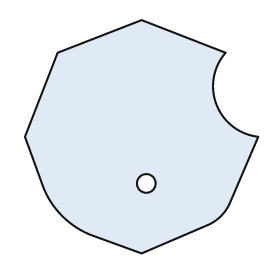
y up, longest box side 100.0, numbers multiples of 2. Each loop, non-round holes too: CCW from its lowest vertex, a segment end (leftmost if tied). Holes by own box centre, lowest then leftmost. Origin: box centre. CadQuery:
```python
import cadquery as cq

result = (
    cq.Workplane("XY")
    .moveTo(0.0, -50.0)
    .lineTo(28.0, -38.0)
    .threePointArc((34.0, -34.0), (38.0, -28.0))
    .lineTo(50.0, 0.0)
    .threePointArc((32.0, 14.0), (36.0, 36.0))
    .lineTo(0.0, 50.0)
    .lineTo(-36.0, 36.0)
    .lineTo(-50.0, 0.0)
    .lineTo(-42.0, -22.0)
    .threePointArc((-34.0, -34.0), (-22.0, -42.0))
    .close()
    .moveTo(2.0, -20.0)
    .circle(4.0)
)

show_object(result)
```